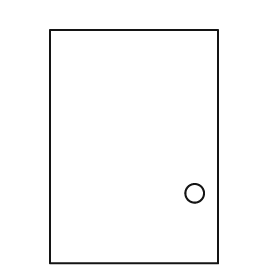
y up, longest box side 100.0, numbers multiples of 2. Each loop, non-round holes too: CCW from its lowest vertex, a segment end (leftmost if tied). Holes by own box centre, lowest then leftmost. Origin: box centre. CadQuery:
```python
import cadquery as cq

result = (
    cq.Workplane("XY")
    .moveTo(-36.0, -50.0)
    .lineTo(36.0, -50.0)
    .lineTo(36.0, 50.0)
    .lineTo(-36.0, 50.0)
    .close()
    .moveTo(26.0, -20.0)
    .circle(4.0)
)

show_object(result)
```